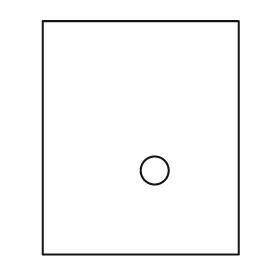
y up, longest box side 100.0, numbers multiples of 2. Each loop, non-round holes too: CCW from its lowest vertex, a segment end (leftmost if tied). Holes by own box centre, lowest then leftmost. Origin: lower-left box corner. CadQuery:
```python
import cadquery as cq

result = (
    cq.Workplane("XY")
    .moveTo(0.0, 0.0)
    .lineTo(84.0, 0.0)
    .lineTo(84.0, 100.0)
    .lineTo(0.0, 100.0)
    .close()
    .moveTo(48.0, 36.0)
    .circle(6.0)
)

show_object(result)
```